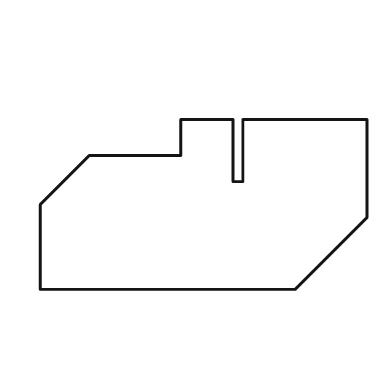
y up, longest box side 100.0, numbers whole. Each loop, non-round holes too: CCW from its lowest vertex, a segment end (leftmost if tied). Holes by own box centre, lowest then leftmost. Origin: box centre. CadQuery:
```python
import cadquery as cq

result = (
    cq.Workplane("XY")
    .moveTo(-50.0, -26.0)
    .lineTo(28.0, -26.0)
    .lineTo(50.0, -4.0)
    .lineTo(50.0, 26.0)
    .lineTo(12.0, 26.0)
    .lineTo(12.0, 7.0)
    .lineTo(9.0, 7.0)
    .lineTo(9.0, 26.0)
    .lineTo(-7.0, 26.0)
    .lineTo(-7.0, 15.0)
    .lineTo(-35.0, 15.0)
    .lineTo(-50.0, 0.0)
    .close()
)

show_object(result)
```